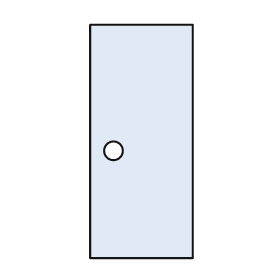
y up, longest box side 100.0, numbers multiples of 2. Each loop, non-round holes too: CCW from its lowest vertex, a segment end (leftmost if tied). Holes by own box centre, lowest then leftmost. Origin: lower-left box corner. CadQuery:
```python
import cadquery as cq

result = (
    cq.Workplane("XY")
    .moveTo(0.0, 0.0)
    .lineTo(44.0, 0.0)
    .lineTo(44.0, 100.0)
    .lineTo(0.0, 100.0)
    .close()
    .moveTo(10.0, 46.0)
    .circle(4.0)
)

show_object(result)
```